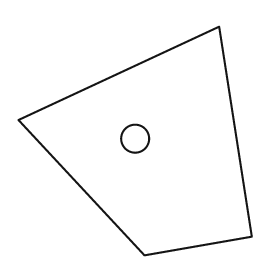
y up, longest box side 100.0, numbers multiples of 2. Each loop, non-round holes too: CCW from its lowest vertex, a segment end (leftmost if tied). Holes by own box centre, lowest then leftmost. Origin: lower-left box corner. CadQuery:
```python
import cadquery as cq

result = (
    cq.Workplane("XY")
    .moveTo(54.0, 0.0)
    .lineTo(100.0, 8.0)
    .lineTo(86.0, 98.0)
    .lineTo(0.0, 58.0)
    .close()
    .moveTo(50.0, 50.0)
    .circle(6.0)
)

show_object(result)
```